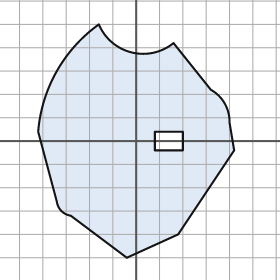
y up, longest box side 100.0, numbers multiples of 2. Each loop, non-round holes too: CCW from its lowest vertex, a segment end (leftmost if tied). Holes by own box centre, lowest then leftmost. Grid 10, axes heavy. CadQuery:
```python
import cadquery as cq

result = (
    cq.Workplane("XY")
    .moveTo(-4.0, -50.0)
    .lineTo(18.0, -40.0)
    .lineTo(42.0, -4.0)
    .lineTo(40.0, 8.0)
    .threePointArc((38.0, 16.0), (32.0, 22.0))
    .lineTo(16.0, 42.0)
    .threePointArc((-2.0, 38.0), (-16.0, 50.0))
    .threePointArc((-34.0, 30.0), (-42.0, 4.0))
    .lineTo(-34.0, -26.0)
    .threePointArc((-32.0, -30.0), (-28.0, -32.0))
    .close()
    .moveTo(8.0, -4.0)
    .lineTo(20.0, -4.0)
    .lineTo(20.0, 4.0)
    .lineTo(8.0, 4.0)
    .close()
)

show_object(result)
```